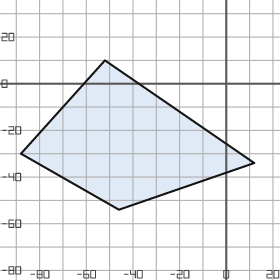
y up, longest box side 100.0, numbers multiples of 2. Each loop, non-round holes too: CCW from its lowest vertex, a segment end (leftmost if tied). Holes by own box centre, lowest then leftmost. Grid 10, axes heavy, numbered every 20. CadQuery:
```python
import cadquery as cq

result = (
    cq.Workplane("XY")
    .moveTo(-46.0, -54.0)
    .lineTo(12.0, -34.0)
    .lineTo(-52.0, 10.0)
    .lineTo(-88.0, -30.0)
    .close()
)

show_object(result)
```